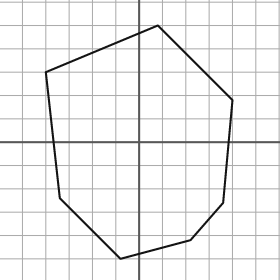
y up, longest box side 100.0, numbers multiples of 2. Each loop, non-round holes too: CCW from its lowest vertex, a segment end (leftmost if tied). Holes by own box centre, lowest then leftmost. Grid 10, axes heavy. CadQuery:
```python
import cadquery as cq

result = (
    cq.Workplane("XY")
    .moveTo(-8.0, -50.0)
    .lineTo(22.0, -42.0)
    .lineTo(36.0, -26.0)
    .lineTo(40.0, 18.0)
    .lineTo(8.0, 50.0)
    .lineTo(-40.0, 30.0)
    .lineTo(-34.0, -24.0)
    .close()
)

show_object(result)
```